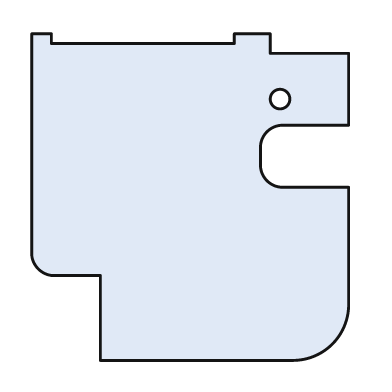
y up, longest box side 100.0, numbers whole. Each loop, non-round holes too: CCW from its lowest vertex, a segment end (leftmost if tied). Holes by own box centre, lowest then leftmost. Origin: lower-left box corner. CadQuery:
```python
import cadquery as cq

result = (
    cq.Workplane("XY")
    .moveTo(21.0, 0.0)
    .lineTo(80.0, 0.0)
    .threePointArc((92.0, 5.0), (97.0, 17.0))
    .lineTo(97.0, 53.0)
    .lineTo(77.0, 53.0)
    .threePointArc((72.0, 55.0), (70.0, 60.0))
    .lineTo(70.0, 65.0)
    .threePointArc((72.0, 70.0), (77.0, 72.0))
    .lineTo(97.0, 72.0)
    .lineTo(97.0, 94.0)
    .lineTo(73.0, 94.0)
    .lineTo(73.0, 100.0)
    .lineTo(62.0, 100.0)
    .lineTo(62.0, 97.0)
    .lineTo(6.0, 97.0)
    .lineTo(6.0, 100.0)
    .lineTo(0.0, 100.0)
    .lineTo(0.0, 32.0)
    .threePointArc((2.0, 28.0), (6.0, 26.0))
    .lineTo(21.0, 26.0)
    .close()
    .moveTo(76.0, 80.0)
    .circle(3.0)
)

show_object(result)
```